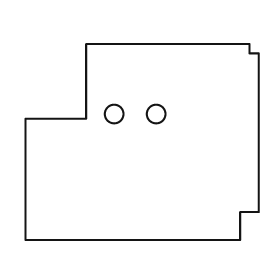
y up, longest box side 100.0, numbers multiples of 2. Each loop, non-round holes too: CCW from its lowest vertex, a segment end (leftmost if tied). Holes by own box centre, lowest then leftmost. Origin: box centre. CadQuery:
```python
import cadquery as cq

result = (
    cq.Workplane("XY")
    .moveTo(-50.0, -42.0)
    .lineTo(42.0, -42.0)
    .lineTo(42.0, -30.0)
    .lineTo(50.0, -30.0)
    .lineTo(50.0, 38.0)
    .lineTo(46.0, 38.0)
    .lineTo(46.0, 42.0)
    .lineTo(-24.0, 42.0)
    .lineTo(-24.0, 10.0)
    .lineTo(-50.0, 10.0)
    .close()
    .moveTo(-12.0, 12.0)
    .circle(4.0)
    .moveTo(6.0, 12.0)
    .circle(4.0)
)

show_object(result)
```